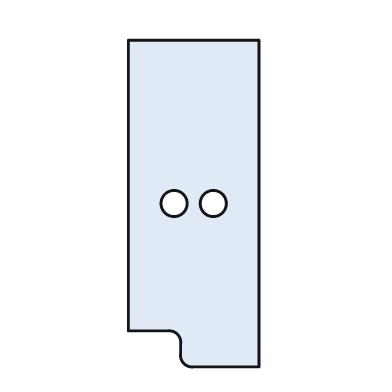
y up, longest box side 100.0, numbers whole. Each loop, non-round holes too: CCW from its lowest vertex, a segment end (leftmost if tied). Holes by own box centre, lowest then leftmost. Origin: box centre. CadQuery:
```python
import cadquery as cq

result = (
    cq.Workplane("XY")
    .moveTo(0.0, -50.0)
    .lineTo(20.0, -50.0)
    .lineTo(20.0, 50.0)
    .lineTo(-20.0, 50.0)
    .lineTo(-20.0, -39.0)
    .lineTo(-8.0, -39.0)
    .threePointArc((-5.0, -40.0), (-4.0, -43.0))
    .lineTo(-4.0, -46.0)
    .threePointArc((-3.0, -49.0), (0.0, -50.0))
    .close()
    .moveTo(-6.0, 0.0)
    .circle(4.0)
    .moveTo(6.0, 0.0)
    .circle(4.0)
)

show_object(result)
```